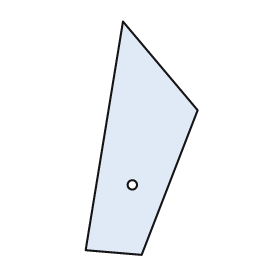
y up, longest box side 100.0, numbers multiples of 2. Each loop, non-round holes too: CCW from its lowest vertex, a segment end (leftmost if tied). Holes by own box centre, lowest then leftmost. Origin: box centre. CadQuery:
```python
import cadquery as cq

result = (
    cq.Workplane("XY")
    .moveTo(0.0, -50.0)
    .lineTo(24.0, 12.0)
    .lineTo(-8.0, 50.0)
    .lineTo(-24.0, -48.0)
    .close()
    .moveTo(-4.0, -20.0)
    .circle(2.0)
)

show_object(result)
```